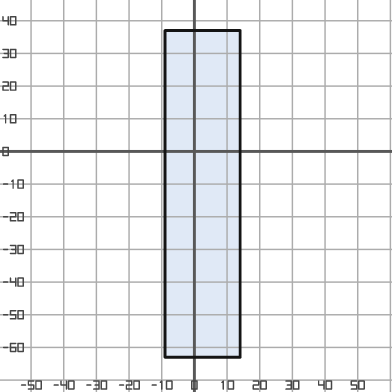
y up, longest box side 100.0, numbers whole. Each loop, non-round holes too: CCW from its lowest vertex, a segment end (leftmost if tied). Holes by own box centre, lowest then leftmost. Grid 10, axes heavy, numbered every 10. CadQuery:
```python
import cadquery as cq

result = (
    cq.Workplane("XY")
    .moveTo(-9.0, -63.0)
    .lineTo(14.0, -63.0)
    .lineTo(14.0, 37.0)
    .lineTo(-9.0, 37.0)
    .close()
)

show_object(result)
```